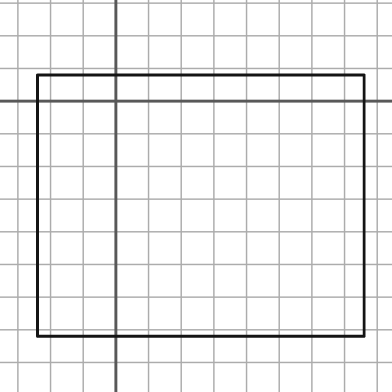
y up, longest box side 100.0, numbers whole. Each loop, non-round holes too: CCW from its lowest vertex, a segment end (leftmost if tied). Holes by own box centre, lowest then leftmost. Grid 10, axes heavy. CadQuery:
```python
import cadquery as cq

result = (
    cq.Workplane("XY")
    .moveTo(-24.0, -72.0)
    .lineTo(76.0, -72.0)
    .lineTo(76.0, 8.0)
    .lineTo(-24.0, 8.0)
    .close()
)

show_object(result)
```